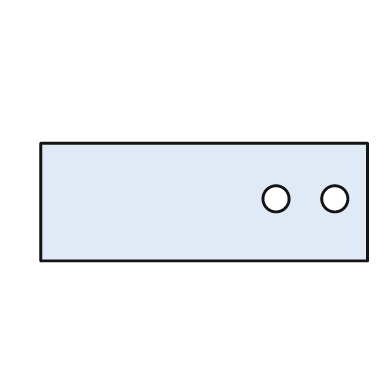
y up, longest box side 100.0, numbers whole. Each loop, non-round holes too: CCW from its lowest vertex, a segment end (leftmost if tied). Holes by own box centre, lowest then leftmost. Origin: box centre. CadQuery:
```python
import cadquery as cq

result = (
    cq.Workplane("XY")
    .moveTo(-50.0, -18.0)
    .lineTo(50.0, -18.0)
    .lineTo(50.0, 18.0)
    .lineTo(-50.0, 18.0)
    .close()
    .moveTo(22.0, 1.0)
    .circle(4.0)
    .moveTo(40.0, 1.0)
    .circle(4.0)
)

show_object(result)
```